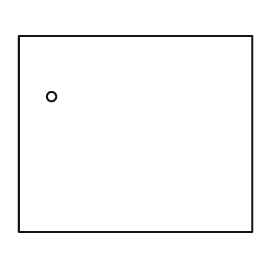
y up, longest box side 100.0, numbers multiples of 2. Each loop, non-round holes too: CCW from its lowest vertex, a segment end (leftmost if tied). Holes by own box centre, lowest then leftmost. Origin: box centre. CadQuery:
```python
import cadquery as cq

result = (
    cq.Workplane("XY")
    .moveTo(-50.0, -42.0)
    .lineTo(50.0, -42.0)
    .lineTo(50.0, 42.0)
    .lineTo(-50.0, 42.0)
    .close()
    .moveTo(-36.0, 16.0)
    .circle(2.0)
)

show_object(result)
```